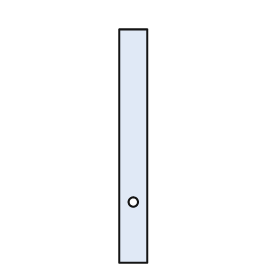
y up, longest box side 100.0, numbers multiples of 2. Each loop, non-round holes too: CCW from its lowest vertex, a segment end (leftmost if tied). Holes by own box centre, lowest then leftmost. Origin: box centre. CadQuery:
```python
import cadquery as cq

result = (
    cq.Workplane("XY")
    .moveTo(-6.0, -50.0)
    .lineTo(6.0, -50.0)
    .lineTo(6.0, 50.0)
    .lineTo(-6.0, 50.0)
    .close()
    .moveTo(0.0, -24.0)
    .circle(2.0)
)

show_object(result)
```